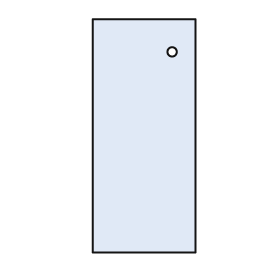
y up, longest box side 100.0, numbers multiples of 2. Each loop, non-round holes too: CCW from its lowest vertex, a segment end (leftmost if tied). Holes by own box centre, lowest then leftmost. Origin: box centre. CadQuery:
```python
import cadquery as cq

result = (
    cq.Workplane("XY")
    .moveTo(-22.0, -50.0)
    .lineTo(22.0, -50.0)
    .lineTo(22.0, 50.0)
    .lineTo(-22.0, 50.0)
    .close()
    .moveTo(12.0, 36.0)
    .circle(2.0)
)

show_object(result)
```